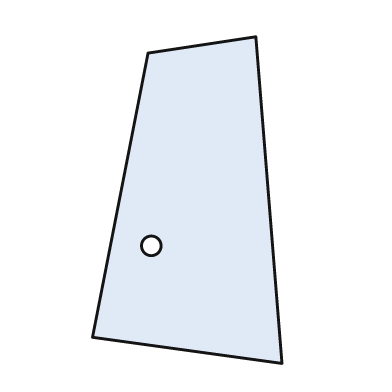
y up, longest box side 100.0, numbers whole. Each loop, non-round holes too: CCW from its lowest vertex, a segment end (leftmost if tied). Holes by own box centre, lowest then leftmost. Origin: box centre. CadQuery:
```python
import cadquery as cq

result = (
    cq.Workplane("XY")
    .moveTo(29.0, -50.0)
    .lineTo(21.0, 50.0)
    .lineTo(-12.0, 45.0)
    .lineTo(-29.0, -42.0)
    .close()
    .moveTo(-11.0, -14.0)
    .circle(3.0)
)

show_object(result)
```